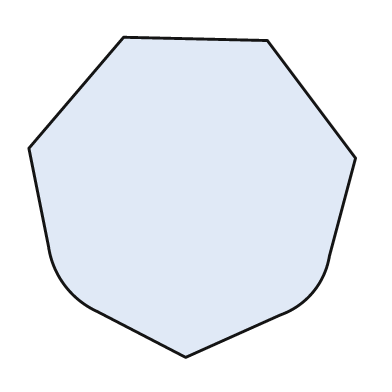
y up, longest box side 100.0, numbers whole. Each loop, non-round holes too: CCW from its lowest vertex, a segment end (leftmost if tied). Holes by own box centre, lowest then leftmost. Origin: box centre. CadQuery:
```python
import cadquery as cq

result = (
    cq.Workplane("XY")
    .moveTo(-2.0, -49.0)
    .lineTo(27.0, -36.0)
    .threePointArc((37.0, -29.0), (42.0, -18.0))
    .lineTo(50.0, 12.0)
    .lineTo(23.0, 48.0)
    .lineTo(-21.0, 49.0)
    .lineTo(-50.0, 15.0)
    .lineTo(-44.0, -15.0)
    .threePointArc((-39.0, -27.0), (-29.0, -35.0))
    .close()
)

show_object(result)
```